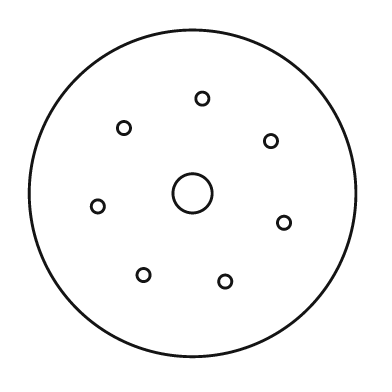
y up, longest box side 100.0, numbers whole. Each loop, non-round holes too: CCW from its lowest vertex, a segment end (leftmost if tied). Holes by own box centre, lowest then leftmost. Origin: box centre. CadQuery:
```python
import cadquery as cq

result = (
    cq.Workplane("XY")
    .moveTo(0.0, 0.0)
    .circle(50.0)
    .moveTo(10.0, -27.0)
    .circle(2.0)
    .moveTo(-15.0, -25.0)
    .circle(2.0)
    .moveTo(28.0, -9.0)
    .circle(2.0)
    .moveTo(-29.0, -4.0)
    .circle(2.0)
    .moveTo(0.0, 0.0)
    .circle(6.0)
    .moveTo(24.0, 16.0)
    .circle(2.0)
    .moveTo(-21.0, 20.0)
    .circle(2.0)
    .moveTo(3.0, 29.0)
    .circle(2.0)
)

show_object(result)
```